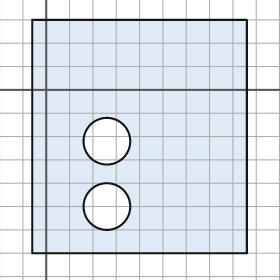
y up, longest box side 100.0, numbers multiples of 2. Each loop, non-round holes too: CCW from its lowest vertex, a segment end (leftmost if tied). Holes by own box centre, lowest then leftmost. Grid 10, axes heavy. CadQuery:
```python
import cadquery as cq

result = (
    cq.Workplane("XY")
    .moveTo(-6.0, -70.0)
    .lineTo(86.0, -70.0)
    .lineTo(86.0, 30.0)
    .lineTo(-6.0, 30.0)
    .close()
    .moveTo(26.0, -50.0)
    .circle(10.0)
    .moveTo(26.0, -22.0)
    .circle(10.0)
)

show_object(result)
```